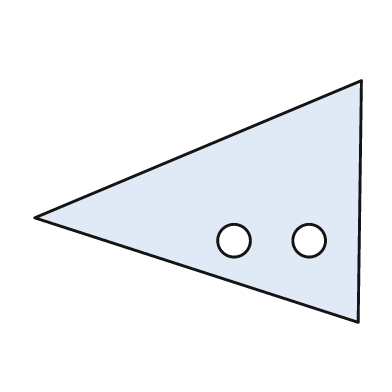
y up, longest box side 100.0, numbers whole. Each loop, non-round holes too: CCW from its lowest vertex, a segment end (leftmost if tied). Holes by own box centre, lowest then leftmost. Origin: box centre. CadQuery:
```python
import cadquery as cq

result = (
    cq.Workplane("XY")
    .moveTo(49.0, -37.0)
    .lineTo(50.0, 37.0)
    .lineTo(-50.0, -5.0)
    .close()
    .moveTo(11.0, -12.0)
    .circle(5.0)
    .moveTo(34.0, -12.0)
    .circle(5.0)
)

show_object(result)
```